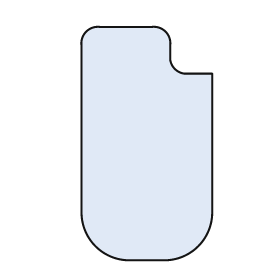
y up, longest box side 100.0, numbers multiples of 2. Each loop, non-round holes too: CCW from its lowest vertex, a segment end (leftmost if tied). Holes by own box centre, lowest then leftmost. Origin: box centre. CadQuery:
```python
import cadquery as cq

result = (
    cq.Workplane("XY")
    .moveTo(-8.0, -50.0)
    .lineTo(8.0, -50.0)
    .threePointArc((22.0, -44.0), (28.0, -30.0))
    .lineTo(28.0, 30.0)
    .lineTo(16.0, 30.0)
    .threePointArc((12.0, 32.0), (10.0, 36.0))
    .lineTo(10.0, 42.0)
    .threePointArc((8.0, 48.0), (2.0, 50.0))
    .lineTo(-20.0, 50.0)
    .threePointArc((-26.0, 48.0), (-28.0, 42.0))
    .lineTo(-28.0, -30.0)
    .threePointArc((-22.0, -44.0), (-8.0, -50.0))
    .close()
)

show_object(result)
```